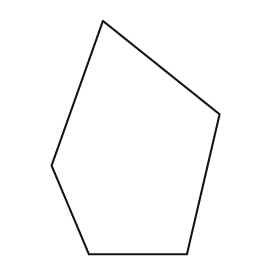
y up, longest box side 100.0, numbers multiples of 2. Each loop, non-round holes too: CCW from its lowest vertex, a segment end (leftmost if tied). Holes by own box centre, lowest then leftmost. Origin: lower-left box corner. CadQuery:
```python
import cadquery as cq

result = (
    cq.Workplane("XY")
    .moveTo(16.0, 0.0)
    .lineTo(58.0, 0.0)
    .lineTo(72.0, 60.0)
    .lineTo(22.0, 100.0)
    .lineTo(0.0, 38.0)
    .close()
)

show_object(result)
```